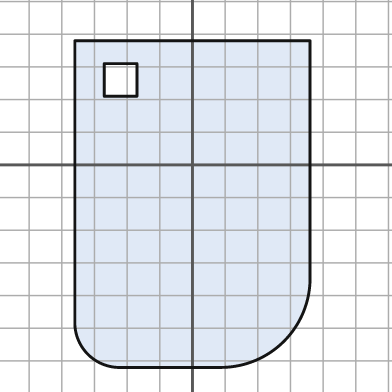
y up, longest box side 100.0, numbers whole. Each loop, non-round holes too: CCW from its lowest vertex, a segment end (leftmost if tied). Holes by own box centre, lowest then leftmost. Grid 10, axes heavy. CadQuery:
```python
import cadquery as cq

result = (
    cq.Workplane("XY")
    .moveTo(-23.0, -62.0)
    .lineTo(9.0, -62.0)
    .threePointArc((28.0, -54.0), (36.0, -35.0))
    .lineTo(36.0, 38.0)
    .lineTo(-36.0, 38.0)
    .lineTo(-36.0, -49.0)
    .threePointArc((-32.0, -58.0), (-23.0, -62.0))
    .close()
    .moveTo(-27.0, 21.0)
    .lineTo(-17.0, 21.0)
    .lineTo(-17.0, 31.0)
    .lineTo(-27.0, 31.0)
    .close()
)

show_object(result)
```